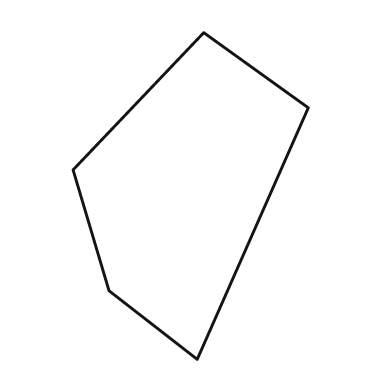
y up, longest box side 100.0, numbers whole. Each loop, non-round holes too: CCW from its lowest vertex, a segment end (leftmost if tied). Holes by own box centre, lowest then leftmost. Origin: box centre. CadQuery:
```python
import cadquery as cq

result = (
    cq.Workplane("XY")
    .moveTo(2.0, -50.0)
    .lineTo(36.0, 27.0)
    .lineTo(4.0, 50.0)
    .lineTo(-36.0, 8.0)
    .lineTo(-25.0, -29.0)
    .close()
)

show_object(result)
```